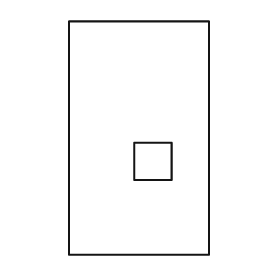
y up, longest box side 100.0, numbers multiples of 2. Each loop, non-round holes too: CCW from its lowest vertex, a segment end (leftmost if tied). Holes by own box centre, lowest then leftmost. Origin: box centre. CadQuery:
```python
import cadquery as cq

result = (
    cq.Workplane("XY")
    .moveTo(-30.0, -50.0)
    .lineTo(30.0, -50.0)
    .lineTo(30.0, 50.0)
    .lineTo(-30.0, 50.0)
    .close()
    .moveTo(-2.0, -18.0)
    .lineTo(14.0, -18.0)
    .lineTo(14.0, -2.0)
    .lineTo(-2.0, -2.0)
    .close()
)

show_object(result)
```